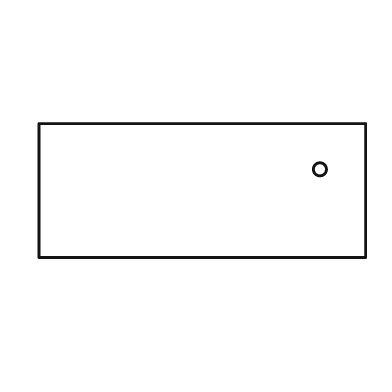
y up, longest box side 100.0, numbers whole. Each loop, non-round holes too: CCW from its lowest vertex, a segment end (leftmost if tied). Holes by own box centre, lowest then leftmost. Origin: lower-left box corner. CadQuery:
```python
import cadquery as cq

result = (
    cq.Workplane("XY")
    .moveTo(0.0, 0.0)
    .lineTo(100.0, 0.0)
    .lineTo(100.0, 41.0)
    .lineTo(0.0, 41.0)
    .close()
    .moveTo(86.0, 27.0)
    .circle(2.0)
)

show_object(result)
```